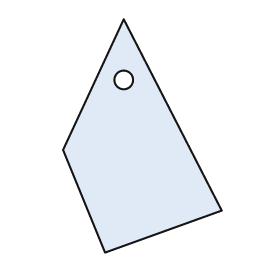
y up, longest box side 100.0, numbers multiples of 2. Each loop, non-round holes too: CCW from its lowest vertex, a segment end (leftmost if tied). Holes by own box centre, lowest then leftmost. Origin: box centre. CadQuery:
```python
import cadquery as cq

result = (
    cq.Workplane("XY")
    .moveTo(-16.0, -50.0)
    .lineTo(34.0, -32.0)
    .lineTo(-8.0, 50.0)
    .lineTo(-34.0, -6.0)
    .close()
    .moveTo(-8.0, 24.0)
    .circle(4.0)
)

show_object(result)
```